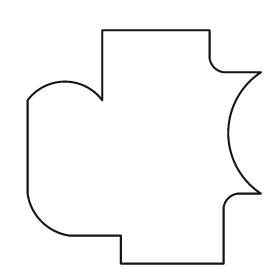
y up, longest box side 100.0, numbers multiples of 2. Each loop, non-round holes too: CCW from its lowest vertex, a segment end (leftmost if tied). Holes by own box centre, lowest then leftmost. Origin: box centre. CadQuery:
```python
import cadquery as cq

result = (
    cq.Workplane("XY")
    .moveTo(-10.0, -50.0)
    .lineTo(34.0, -50.0)
    .lineTo(34.0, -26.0)
    .threePointArc((36.0, -22.0), (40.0, -20.0))
    .lineTo(50.0, -20.0)
    .threePointArc((36.0, 6.0), (50.0, 32.0))
    .lineTo(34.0, 32.0)
    .threePointArc((30.0, 34.0), (28.0, 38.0))
    .lineTo(28.0, 50.0)
    .lineTo(-18.0, 50.0)
    .lineTo(-18.0, 20.0)
    .threePointArc((-34.0, 28.0), (-50.0, 20.0))
    .lineTo(-50.0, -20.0)
    .threePointArc((-44.0, -32.0), (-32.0, -38.0))
    .lineTo(-10.0, -38.0)
    .close()
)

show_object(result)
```